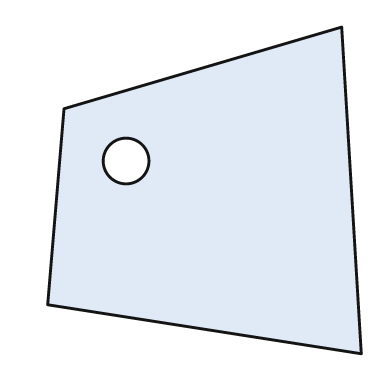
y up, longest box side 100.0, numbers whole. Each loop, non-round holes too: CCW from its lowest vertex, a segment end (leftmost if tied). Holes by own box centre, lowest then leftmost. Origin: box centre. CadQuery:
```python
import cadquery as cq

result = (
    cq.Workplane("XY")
    .moveTo(48.0, -50.0)
    .lineTo(42.0, 50.0)
    .lineTo(-43.0, 25.0)
    .lineTo(-48.0, -35.0)
    .close()
    .moveTo(-24.0, 9.0)
    .circle(7.0)
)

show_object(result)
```